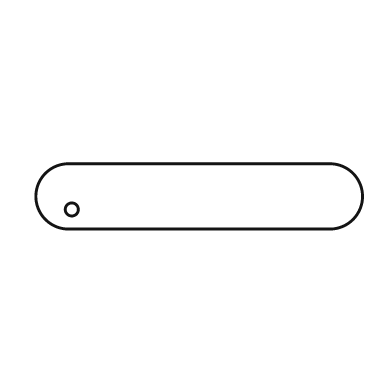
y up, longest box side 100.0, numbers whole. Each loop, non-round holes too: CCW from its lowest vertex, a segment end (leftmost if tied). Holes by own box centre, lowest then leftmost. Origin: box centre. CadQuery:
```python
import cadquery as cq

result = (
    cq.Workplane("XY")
    .moveTo(-40.0, -10.0)
    .lineTo(40.0, -10.0)
    .threePointArc((50.0, 0.0), (40.0, 10.0))
    .lineTo(-40.0, 10.0)
    .threePointArc((-50.0, 0.0), (-40.0, -10.0))
    .close()
    .moveTo(-39.0, -4.0)
    .circle(2.0)
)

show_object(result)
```